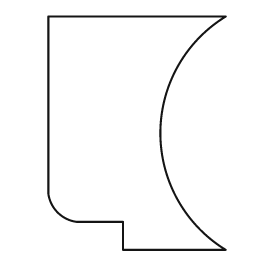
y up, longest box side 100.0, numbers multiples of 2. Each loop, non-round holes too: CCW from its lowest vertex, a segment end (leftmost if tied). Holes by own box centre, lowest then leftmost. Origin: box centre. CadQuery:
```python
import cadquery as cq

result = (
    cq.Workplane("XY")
    .moveTo(-6.0, -50.0)
    .lineTo(38.0, -50.0)
    .threePointArc((10.0, 0.0), (38.0, 50.0))
    .lineTo(-38.0, 50.0)
    .lineTo(-38.0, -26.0)
    .threePointArc((-34.0, -34.0), (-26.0, -38.0))
    .lineTo(-6.0, -38.0)
    .close()
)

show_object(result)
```